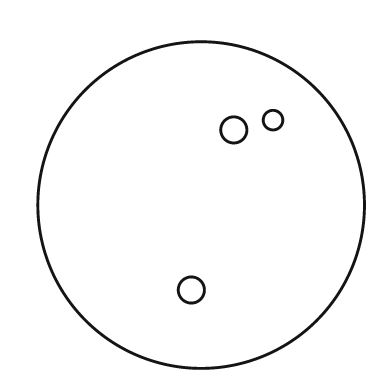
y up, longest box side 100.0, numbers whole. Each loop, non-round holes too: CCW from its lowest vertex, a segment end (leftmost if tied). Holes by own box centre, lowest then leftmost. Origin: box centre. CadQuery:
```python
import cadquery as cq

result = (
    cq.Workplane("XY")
    .moveTo(0.0, 0.0)
    .circle(50.0)
    .moveTo(-3.0, -26.0)
    .circle(4.0)
    .moveTo(10.0, 23.0)
    .circle(4.0)
    .moveTo(22.0, 26.0)
    .circle(3.0)
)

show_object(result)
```